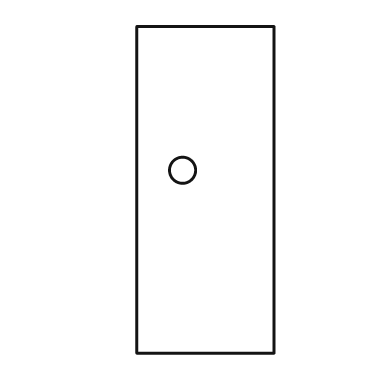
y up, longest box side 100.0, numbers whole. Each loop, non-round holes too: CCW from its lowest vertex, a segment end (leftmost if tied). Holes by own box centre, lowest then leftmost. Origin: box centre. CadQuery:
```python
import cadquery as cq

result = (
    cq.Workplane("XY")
    .moveTo(-21.0, -50.0)
    .lineTo(21.0, -50.0)
    .lineTo(21.0, 50.0)
    .lineTo(-21.0, 50.0)
    .close()
    .moveTo(-7.0, 6.0)
    .circle(4.0)
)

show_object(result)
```